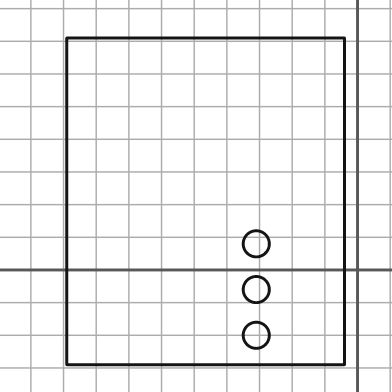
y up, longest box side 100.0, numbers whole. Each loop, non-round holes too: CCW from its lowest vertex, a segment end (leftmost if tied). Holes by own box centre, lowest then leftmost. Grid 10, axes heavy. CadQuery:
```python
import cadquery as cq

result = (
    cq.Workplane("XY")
    .moveTo(-89.0, -29.0)
    .lineTo(-4.0, -29.0)
    .lineTo(-4.0, 71.0)
    .lineTo(-89.0, 71.0)
    .close()
    .moveTo(-31.0, -20.0)
    .circle(4.0)
    .moveTo(-31.0, -6.0)
    .circle(4.0)
    .moveTo(-31.0, 8.0)
    .circle(4.0)
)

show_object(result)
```